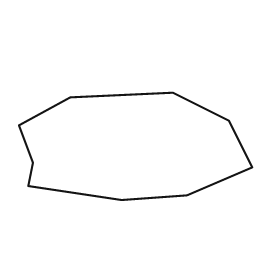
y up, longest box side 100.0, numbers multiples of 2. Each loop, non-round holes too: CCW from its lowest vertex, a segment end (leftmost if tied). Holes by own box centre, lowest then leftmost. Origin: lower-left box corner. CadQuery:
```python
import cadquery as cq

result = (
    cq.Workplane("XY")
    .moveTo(44.0, 0.0)
    .lineTo(72.0, 2.0)
    .lineTo(100.0, 14.0)
    .lineTo(90.0, 34.0)
    .lineTo(66.0, 46.0)
    .lineTo(22.0, 44.0)
    .lineTo(0.0, 32.0)
    .lineTo(6.0, 16.0)
    .lineTo(4.0, 6.0)
    .close()
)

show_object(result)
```